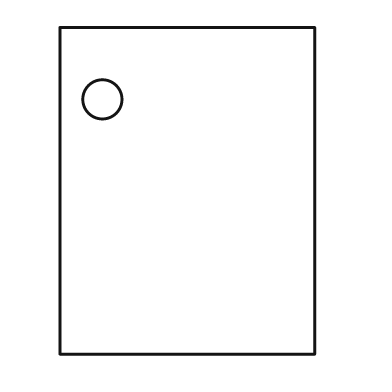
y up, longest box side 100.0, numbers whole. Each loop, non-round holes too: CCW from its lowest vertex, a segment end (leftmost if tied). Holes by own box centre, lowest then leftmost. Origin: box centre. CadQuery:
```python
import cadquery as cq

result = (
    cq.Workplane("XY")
    .moveTo(-39.0, -50.0)
    .lineTo(39.0, -50.0)
    .lineTo(39.0, 50.0)
    .lineTo(-39.0, 50.0)
    .close()
    .moveTo(-26.0, 28.0)
    .circle(6.0)
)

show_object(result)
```